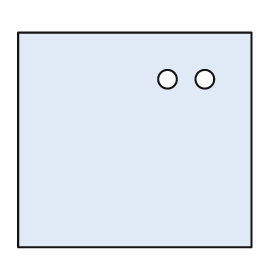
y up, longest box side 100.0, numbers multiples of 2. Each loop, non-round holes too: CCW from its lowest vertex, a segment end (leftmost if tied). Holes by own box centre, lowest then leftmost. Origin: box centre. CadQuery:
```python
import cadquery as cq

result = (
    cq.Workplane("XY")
    .moveTo(-50.0, -46.0)
    .lineTo(50.0, -46.0)
    .lineTo(50.0, 46.0)
    .lineTo(-50.0, 46.0)
    .close()
    .moveTo(14.0, 26.0)
    .circle(4.0)
    .moveTo(30.0, 26.0)
    .circle(4.0)
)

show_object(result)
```